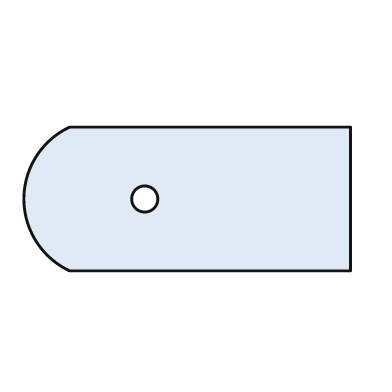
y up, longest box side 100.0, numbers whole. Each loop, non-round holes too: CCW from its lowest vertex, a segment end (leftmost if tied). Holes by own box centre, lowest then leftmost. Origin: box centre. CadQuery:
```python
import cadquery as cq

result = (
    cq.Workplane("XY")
    .moveTo(-36.0, -22.0)
    .lineTo(50.0, -22.0)
    .lineTo(50.0, 22.0)
    .lineTo(-36.0, 22.0)
    .threePointArc((-50.0, 0.0), (-36.0, -22.0))
    .close()
    .moveTo(-13.0, 0.0)
    .circle(4.0)
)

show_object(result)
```